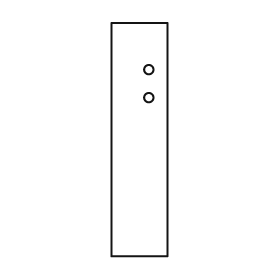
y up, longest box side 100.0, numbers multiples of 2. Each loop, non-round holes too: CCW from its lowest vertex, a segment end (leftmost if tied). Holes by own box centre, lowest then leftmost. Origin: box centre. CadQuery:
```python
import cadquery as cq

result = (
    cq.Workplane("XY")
    .moveTo(-12.0, -50.0)
    .lineTo(12.0, -50.0)
    .lineTo(12.0, 50.0)
    .lineTo(-12.0, 50.0)
    .close()
    .moveTo(4.0, 18.0)
    .circle(2.0)
    .moveTo(4.0, 30.0)
    .circle(2.0)
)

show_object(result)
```